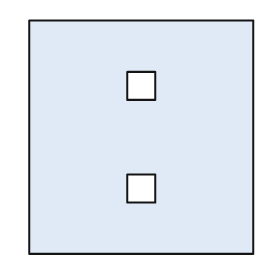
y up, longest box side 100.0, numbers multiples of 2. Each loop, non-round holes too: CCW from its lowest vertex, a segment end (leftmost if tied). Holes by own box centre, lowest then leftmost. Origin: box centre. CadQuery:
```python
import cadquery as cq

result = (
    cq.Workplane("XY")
    .moveTo(-48.0, -50.0)
    .lineTo(48.0, -50.0)
    .lineTo(48.0, 50.0)
    .lineTo(-48.0, 50.0)
    .close()
    .moveTo(-6.0, -28.0)
    .lineTo(6.0, -28.0)
    .lineTo(6.0, -16.0)
    .lineTo(-6.0, -16.0)
    .close()
    .moveTo(-6.0, 16.0)
    .lineTo(6.0, 16.0)
    .lineTo(6.0, 28.0)
    .lineTo(-6.0, 28.0)
    .close()
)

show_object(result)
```